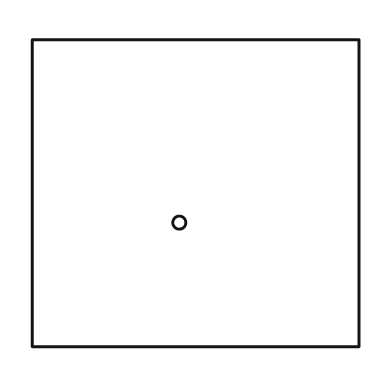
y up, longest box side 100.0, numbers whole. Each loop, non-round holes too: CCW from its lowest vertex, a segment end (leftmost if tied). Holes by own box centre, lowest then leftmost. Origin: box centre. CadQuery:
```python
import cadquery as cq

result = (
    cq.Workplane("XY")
    .moveTo(-50.0, -47.0)
    .lineTo(50.0, -47.0)
    .lineTo(50.0, 47.0)
    .lineTo(-50.0, 47.0)
    .close()
    .moveTo(-5.0, -9.0)
    .circle(2.0)
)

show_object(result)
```